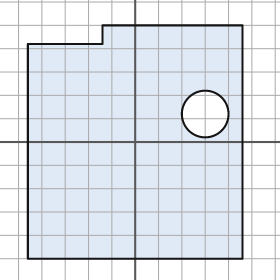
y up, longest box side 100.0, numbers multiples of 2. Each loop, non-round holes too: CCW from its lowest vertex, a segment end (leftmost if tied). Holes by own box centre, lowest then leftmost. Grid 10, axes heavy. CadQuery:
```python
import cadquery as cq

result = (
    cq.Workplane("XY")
    .moveTo(-46.0, -50.0)
    .lineTo(46.0, -50.0)
    .lineTo(46.0, 50.0)
    .lineTo(-14.0, 50.0)
    .lineTo(-14.0, 42.0)
    .lineTo(-46.0, 42.0)
    .close()
    .moveTo(30.0, 12.0)
    .circle(10.0)
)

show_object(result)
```